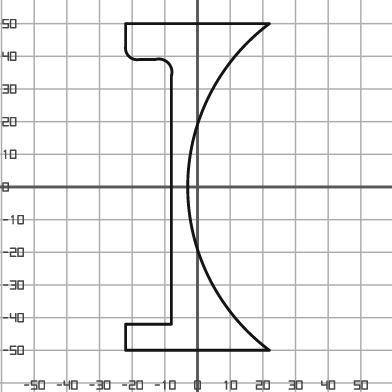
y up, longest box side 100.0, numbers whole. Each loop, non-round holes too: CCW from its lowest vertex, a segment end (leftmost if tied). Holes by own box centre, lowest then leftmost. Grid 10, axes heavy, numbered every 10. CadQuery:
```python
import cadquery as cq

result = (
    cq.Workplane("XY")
    .moveTo(-22.0, -50.0)
    .lineTo(22.0, -50.0)
    .threePointArc((-3.0, 0.0), (22.0, 50.0))
    .lineTo(-22.0, 50.0)
    .lineTo(-22.0, 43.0)
    .threePointArc((-21.0, 40.0), (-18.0, 39.0))
    .lineTo(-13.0, 39.0)
    .threePointArc((-9.0, 38.0), (-8.0, 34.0))
    .lineTo(-8.0, -42.0)
    .lineTo(-22.0, -42.0)
    .close()
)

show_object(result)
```